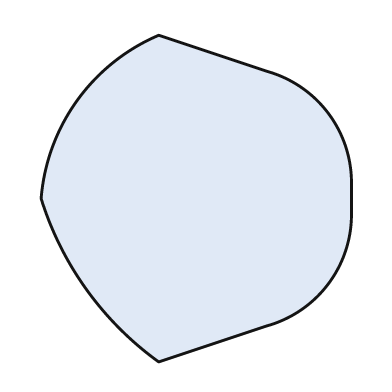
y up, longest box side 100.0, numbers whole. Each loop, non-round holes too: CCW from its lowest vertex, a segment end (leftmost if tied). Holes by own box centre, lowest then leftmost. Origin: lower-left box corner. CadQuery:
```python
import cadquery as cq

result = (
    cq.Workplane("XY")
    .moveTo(36.0, 0.0)
    .lineTo(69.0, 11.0)
    .threePointArc((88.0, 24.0), (95.0, 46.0))
    .lineTo(95.0, 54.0)
    .threePointArc((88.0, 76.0), (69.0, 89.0))
    .lineTo(36.0, 100.0)
    .threePointArc((11.0, 80.0), (0.0, 50.0))
    .threePointArc((14.0, 22.0), (36.0, 0.0))
    .close()
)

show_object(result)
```